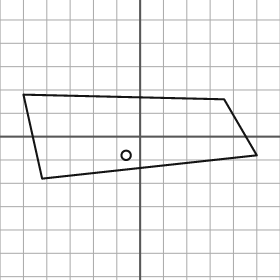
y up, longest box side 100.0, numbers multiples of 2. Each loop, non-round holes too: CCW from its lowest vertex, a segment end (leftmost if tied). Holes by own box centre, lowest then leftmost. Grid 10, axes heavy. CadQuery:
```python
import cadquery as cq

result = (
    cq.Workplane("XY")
    .moveTo(-42.0, -18.0)
    .lineTo(50.0, -8.0)
    .lineTo(36.0, 16.0)
    .lineTo(-50.0, 18.0)
    .close()
    .moveTo(-6.0, -8.0)
    .circle(2.0)
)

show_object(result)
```